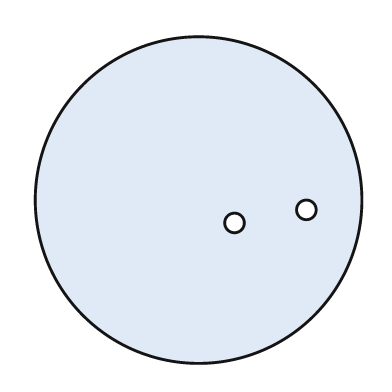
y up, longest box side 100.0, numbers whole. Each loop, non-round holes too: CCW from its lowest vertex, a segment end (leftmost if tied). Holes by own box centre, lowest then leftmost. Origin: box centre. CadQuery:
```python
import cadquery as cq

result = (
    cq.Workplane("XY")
    .moveTo(0.0, 0.0)
    .circle(50.0)
    .moveTo(11.0, -7.0)
    .circle(3.0)
    .moveTo(33.0, -3.0)
    .circle(3.0)
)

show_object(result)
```